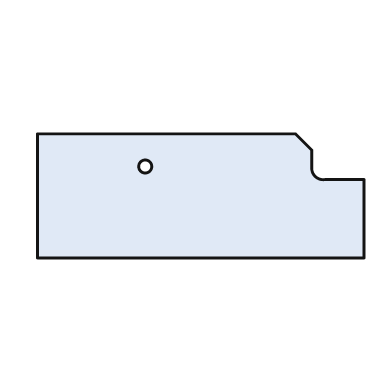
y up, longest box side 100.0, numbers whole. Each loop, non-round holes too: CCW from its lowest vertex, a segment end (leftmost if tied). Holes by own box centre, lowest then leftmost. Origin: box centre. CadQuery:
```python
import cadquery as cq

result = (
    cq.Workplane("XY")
    .moveTo(-50.0, -19.0)
    .lineTo(50.0, -19.0)
    .lineTo(50.0, 5.0)
    .lineTo(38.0, 5.0)
    .threePointArc((35.0, 6.0), (34.0, 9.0))
    .lineTo(34.0, 14.0)
    .lineTo(29.0, 19.0)
    .lineTo(-50.0, 19.0)
    .close()
    .moveTo(-17.0, 9.0)
    .circle(2.0)
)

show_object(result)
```